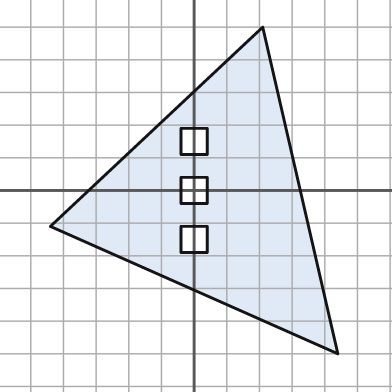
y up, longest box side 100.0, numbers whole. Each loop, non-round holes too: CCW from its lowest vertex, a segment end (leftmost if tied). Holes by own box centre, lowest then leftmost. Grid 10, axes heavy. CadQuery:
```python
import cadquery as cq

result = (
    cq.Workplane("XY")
    .moveTo(44.0, -50.0)
    .lineTo(21.0, 50.0)
    .lineTo(-44.0, -11.0)
    .close()
    .moveTo(-4.0, -19.0)
    .lineTo(4.0, -19.0)
    .lineTo(4.0, -11.0)
    .lineTo(-4.0, -11.0)
    .close()
    .moveTo(-4.0, -4.0)
    .lineTo(4.0, -4.0)
    .lineTo(4.0, 4.0)
    .lineTo(-4.0, 4.0)
    .close()
    .moveTo(-4.0, 11.0)
    .lineTo(4.0, 11.0)
    .lineTo(4.0, 19.0)
    .lineTo(-4.0, 19.0)
    .close()
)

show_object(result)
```